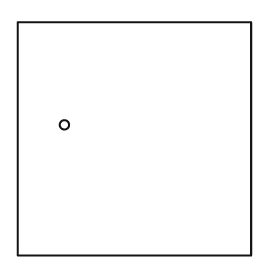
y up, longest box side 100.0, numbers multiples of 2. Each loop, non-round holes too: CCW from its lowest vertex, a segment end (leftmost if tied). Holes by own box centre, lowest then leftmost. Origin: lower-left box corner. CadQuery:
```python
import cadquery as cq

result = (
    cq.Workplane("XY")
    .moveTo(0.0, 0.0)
    .lineTo(100.0, 0.0)
    .lineTo(100.0, 100.0)
    .lineTo(0.0, 100.0)
    .close()
    .moveTo(20.0, 56.0)
    .circle(2.0)
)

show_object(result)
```